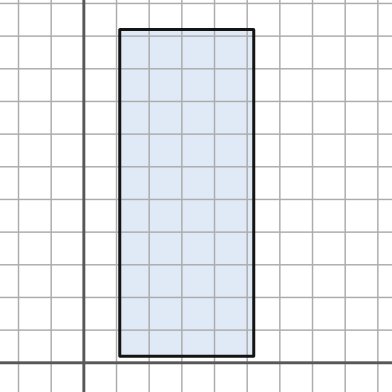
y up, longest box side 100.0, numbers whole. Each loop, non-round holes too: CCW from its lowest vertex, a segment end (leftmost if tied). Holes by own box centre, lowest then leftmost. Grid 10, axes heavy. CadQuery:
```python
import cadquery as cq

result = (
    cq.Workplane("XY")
    .moveTo(11.0, 2.0)
    .lineTo(52.0, 2.0)
    .lineTo(52.0, 102.0)
    .lineTo(11.0, 102.0)
    .close()
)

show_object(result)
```